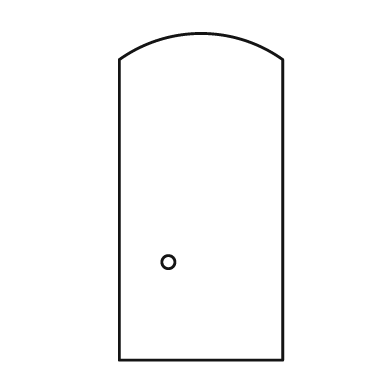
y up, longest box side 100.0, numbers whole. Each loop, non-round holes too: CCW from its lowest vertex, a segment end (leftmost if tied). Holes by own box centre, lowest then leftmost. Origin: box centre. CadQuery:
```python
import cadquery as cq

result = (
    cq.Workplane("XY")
    .moveTo(-25.0, -50.0)
    .lineTo(25.0, -50.0)
    .lineTo(25.0, 42.0)
    .threePointArc((0.0, 50.0), (-25.0, 42.0))
    .close()
    .moveTo(-10.0, -20.0)
    .circle(2.0)
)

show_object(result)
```